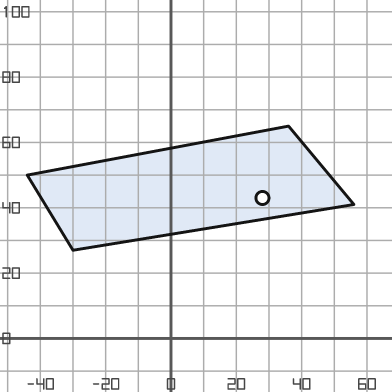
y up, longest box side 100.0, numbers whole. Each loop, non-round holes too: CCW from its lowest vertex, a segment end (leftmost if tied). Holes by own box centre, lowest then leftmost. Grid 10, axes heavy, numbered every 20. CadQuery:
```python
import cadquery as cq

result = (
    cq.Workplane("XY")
    .moveTo(-30.0, 27.0)
    .lineTo(56.0, 41.0)
    .lineTo(36.0, 65.0)
    .lineTo(-44.0, 50.0)
    .close()
    .moveTo(28.0, 43.0)
    .circle(2.0)
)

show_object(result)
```